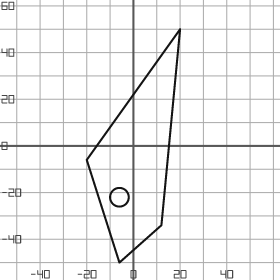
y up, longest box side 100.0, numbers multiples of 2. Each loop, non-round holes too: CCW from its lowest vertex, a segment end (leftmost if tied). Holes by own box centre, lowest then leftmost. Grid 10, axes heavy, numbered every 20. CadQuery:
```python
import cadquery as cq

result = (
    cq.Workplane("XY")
    .moveTo(-6.0, -50.0)
    .lineTo(12.0, -34.0)
    .lineTo(20.0, 50.0)
    .lineTo(-20.0, -6.0)
    .close()
    .moveTo(-6.0, -22.0)
    .circle(4.0)
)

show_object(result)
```